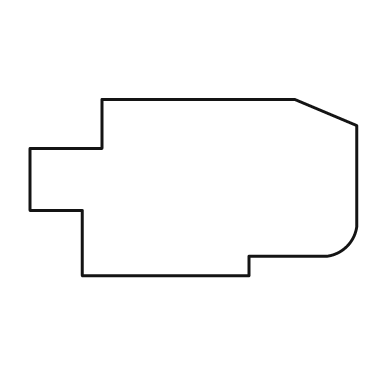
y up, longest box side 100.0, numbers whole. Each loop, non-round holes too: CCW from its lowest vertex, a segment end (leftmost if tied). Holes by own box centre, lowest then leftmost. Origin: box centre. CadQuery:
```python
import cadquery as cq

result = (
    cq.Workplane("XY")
    .moveTo(-34.0, -27.0)
    .lineTo(17.0, -27.0)
    .lineTo(17.0, -21.0)
    .lineTo(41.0, -21.0)
    .threePointArc((47.0, -18.0), (50.0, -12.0))
    .lineTo(50.0, 19.0)
    .lineTo(31.0, 27.0)
    .lineTo(-28.0, 27.0)
    .lineTo(-28.0, 12.0)
    .lineTo(-50.0, 12.0)
    .lineTo(-50.0, -7.0)
    .lineTo(-34.0, -7.0)
    .close()
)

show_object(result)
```